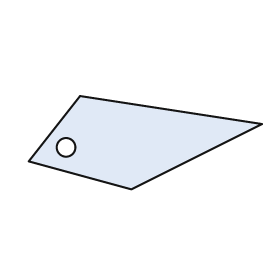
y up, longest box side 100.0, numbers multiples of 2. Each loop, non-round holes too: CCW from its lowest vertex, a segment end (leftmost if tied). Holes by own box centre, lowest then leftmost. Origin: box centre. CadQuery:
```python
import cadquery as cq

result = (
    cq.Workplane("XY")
    .moveTo(-6.0, -20.0)
    .lineTo(50.0, 8.0)
    .lineTo(-28.0, 20.0)
    .lineTo(-50.0, -8.0)
    .close()
    .moveTo(-34.0, -2.0)
    .circle(4.0)
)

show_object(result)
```